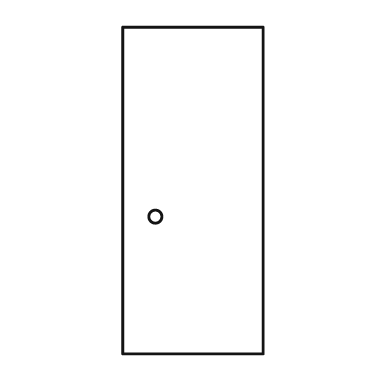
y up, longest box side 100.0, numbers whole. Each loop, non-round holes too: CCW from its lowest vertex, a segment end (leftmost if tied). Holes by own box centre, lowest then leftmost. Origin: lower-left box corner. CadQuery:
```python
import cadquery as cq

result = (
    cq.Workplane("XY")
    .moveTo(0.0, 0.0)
    .lineTo(43.0, 0.0)
    .lineTo(43.0, 100.0)
    .lineTo(0.0, 100.0)
    .close()
    .moveTo(10.0, 42.0)
    .circle(2.0)
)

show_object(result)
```